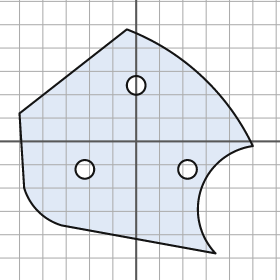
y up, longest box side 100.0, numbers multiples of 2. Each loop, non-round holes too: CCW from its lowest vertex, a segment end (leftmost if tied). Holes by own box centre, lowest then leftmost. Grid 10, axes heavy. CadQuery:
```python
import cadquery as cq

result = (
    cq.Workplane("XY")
    .moveTo(34.0, -48.0)
    .threePointArc((28.0, -20.0), (50.0, -2.0))
    .threePointArc((28.0, 28.0), (-4.0, 48.0))
    .lineTo(-50.0, 12.0)
    .lineTo(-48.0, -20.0)
    .threePointArc((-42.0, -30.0), (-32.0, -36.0))
    .close()
    .moveTo(-22.0, -12.0)
    .circle(4.0)
    .moveTo(22.0, -12.0)
    .circle(4.0)
    .moveTo(0.0, 24.0)
    .circle(4.0)
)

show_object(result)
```